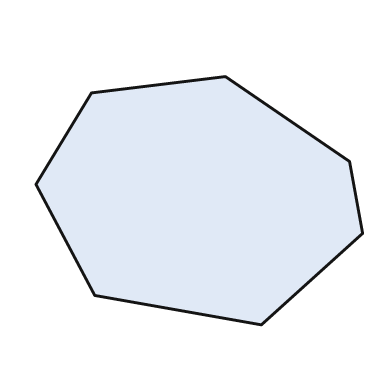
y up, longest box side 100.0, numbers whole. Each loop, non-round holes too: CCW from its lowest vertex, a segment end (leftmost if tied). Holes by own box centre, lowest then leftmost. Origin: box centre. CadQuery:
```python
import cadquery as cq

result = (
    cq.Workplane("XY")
    .moveTo(19.0, -38.0)
    .lineTo(50.0, -10.0)
    .lineTo(46.0, 12.0)
    .lineTo(8.0, 38.0)
    .lineTo(-33.0, 33.0)
    .lineTo(-50.0, 5.0)
    .lineTo(-32.0, -29.0)
    .close()
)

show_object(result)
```